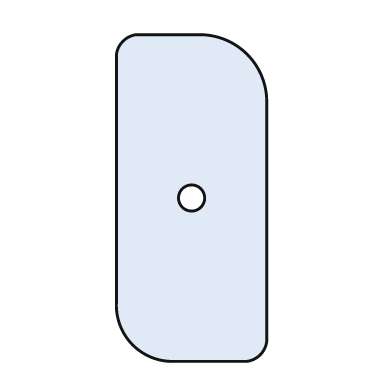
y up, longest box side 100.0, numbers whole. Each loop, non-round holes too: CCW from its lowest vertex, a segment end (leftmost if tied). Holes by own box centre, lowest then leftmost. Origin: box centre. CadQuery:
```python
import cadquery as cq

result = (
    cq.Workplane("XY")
    .moveTo(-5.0, -50.0)
    .lineTo(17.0, -50.0)
    .threePointArc((21.0, -48.0), (23.0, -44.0))
    .lineTo(23.0, 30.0)
    .threePointArc((17.0, 44.0), (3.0, 50.0))
    .lineTo(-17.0, 50.0)
    .threePointArc((-21.0, 48.0), (-23.0, 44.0))
    .lineTo(-23.0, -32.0)
    .threePointArc((-18.0, -45.0), (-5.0, -50.0))
    .close()
    .moveTo(0.0, 0.0)
    .circle(4.0)
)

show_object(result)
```